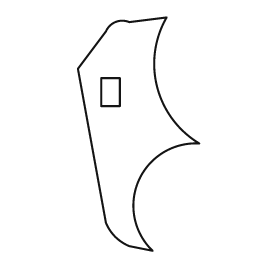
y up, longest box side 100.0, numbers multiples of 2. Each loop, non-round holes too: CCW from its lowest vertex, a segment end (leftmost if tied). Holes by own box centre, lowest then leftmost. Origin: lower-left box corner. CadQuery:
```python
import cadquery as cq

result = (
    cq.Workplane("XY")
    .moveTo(32.0, 0.0)
    .threePointArc((26.0, 30.0), (52.0, 46.0))
    .threePointArc((34.0, 70.0), (38.0, 100.0))
    .lineTo(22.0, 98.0)
    .threePointArc((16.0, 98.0), (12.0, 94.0))
    .lineTo(0.0, 78.0)
    .lineTo(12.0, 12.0)
    .threePointArc((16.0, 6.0), (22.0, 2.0))
    .close()
    .moveTo(10.0, 62.0)
    .lineTo(18.0, 62.0)
    .lineTo(18.0, 74.0)
    .lineTo(10.0, 74.0)
    .close()
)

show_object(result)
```